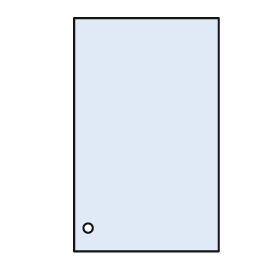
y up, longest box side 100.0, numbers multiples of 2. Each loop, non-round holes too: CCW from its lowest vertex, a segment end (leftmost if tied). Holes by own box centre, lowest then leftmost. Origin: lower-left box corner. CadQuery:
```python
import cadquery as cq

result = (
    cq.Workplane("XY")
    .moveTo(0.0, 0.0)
    .lineTo(62.0, 0.0)
    .lineTo(62.0, 100.0)
    .lineTo(0.0, 100.0)
    .close()
    .moveTo(6.0, 10.0)
    .circle(2.0)
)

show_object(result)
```